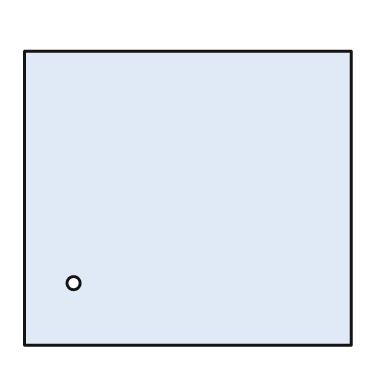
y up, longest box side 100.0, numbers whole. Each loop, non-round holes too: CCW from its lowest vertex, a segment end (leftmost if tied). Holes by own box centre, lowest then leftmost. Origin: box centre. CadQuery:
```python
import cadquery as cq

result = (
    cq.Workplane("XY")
    .moveTo(-50.0, -45.0)
    .lineTo(50.0, -45.0)
    .lineTo(50.0, 45.0)
    .lineTo(-50.0, 45.0)
    .close()
    .moveTo(-35.0, -26.0)
    .circle(2.0)
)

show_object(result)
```